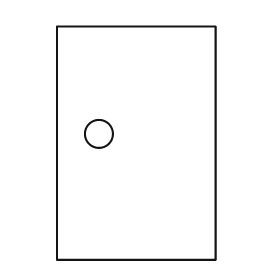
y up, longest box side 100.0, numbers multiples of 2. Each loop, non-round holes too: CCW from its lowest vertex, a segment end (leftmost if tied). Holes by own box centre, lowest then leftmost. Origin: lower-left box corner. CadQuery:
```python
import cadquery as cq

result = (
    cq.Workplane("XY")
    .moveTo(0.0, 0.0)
    .lineTo(68.0, 0.0)
    .lineTo(68.0, 100.0)
    .lineTo(0.0, 100.0)
    .close()
    .moveTo(18.0, 54.0)
    .circle(6.0)
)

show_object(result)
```